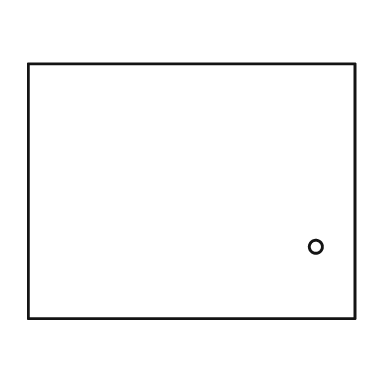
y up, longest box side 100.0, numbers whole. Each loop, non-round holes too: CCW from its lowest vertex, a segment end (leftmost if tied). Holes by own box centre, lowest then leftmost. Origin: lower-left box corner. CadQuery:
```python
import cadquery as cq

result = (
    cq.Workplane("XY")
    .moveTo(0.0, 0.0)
    .lineTo(100.0, 0.0)
    .lineTo(100.0, 78.0)
    .lineTo(0.0, 78.0)
    .close()
    .moveTo(88.0, 22.0)
    .circle(2.0)
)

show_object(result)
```